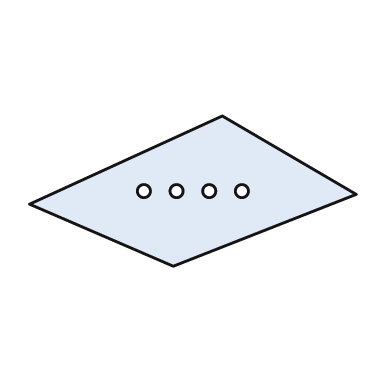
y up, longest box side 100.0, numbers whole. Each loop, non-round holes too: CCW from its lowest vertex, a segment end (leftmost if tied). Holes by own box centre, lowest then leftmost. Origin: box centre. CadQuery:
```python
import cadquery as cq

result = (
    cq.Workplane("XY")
    .moveTo(-6.0, -23.0)
    .lineTo(50.0, -1.0)
    .lineTo(9.0, 23.0)
    .lineTo(-50.0, -4.0)
    .close()
    .moveTo(-15.0, 0.0)
    .circle(2.0)
    .moveTo(-5.0, 0.0)
    .circle(2.0)
    .moveTo(5.0, 0.0)
    .circle(2.0)
    .moveTo(15.0, 0.0)
    .circle(2.0)
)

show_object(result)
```